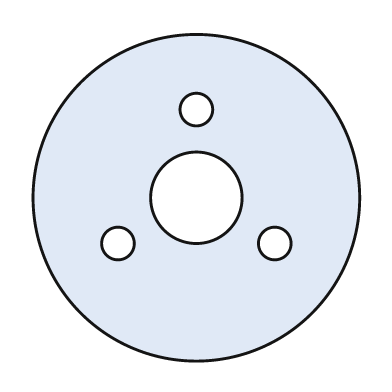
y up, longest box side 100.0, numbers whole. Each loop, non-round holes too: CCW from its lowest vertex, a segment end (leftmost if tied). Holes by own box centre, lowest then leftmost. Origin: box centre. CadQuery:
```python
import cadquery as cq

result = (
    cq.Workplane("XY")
    .moveTo(0.0, 0.0)
    .circle(50.0)
    .moveTo(-24.0, -14.0)
    .circle(5.0)
    .moveTo(24.0, -14.0)
    .circle(5.0)
    .moveTo(0.0, 0.0)
    .circle(14.0)
    .moveTo(0.0, 27.0)
    .circle(5.0)
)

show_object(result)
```